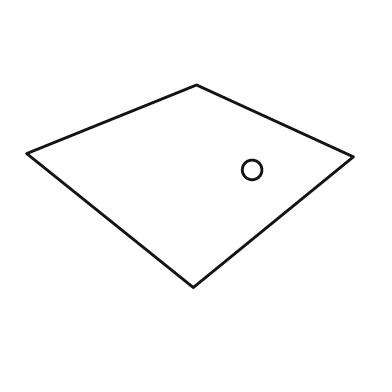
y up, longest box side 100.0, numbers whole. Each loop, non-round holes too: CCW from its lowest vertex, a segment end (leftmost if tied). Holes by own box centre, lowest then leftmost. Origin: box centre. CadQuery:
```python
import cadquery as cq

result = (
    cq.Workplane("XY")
    .moveTo(1.0, -31.0)
    .lineTo(50.0, 9.0)
    .lineTo(2.0, 31.0)
    .lineTo(-50.0, 10.0)
    .close()
    .moveTo(19.0, 5.0)
    .circle(3.0)
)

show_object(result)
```